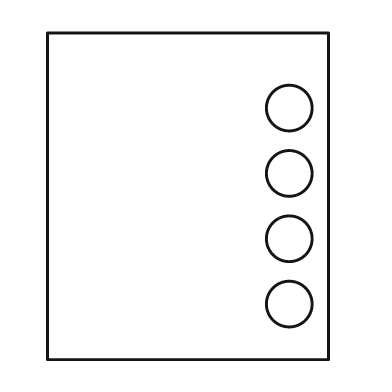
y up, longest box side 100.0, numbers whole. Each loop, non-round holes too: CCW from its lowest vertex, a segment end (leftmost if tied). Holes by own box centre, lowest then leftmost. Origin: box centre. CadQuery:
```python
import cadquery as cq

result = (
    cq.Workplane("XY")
    .moveTo(-43.0, -50.0)
    .lineTo(43.0, -50.0)
    .lineTo(43.0, 50.0)
    .lineTo(-43.0, 50.0)
    .close()
    .moveTo(31.0, -33.0)
    .circle(7.0)
    .moveTo(31.0, -13.0)
    .circle(7.0)
    .moveTo(31.0, 7.0)
    .circle(7.0)
    .moveTo(31.0, 27.0)
    .circle(7.0)
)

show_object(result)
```